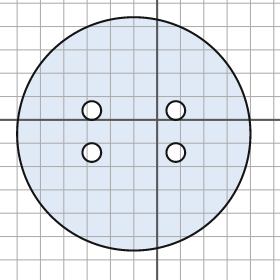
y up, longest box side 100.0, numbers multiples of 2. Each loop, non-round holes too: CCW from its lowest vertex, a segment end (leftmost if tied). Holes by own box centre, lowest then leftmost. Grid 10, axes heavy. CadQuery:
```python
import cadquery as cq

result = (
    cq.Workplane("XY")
    .moveTo(-10.0, -6.0)
    .circle(50.0)
    .moveTo(-28.0, -14.0)
    .circle(4.0)
    .moveTo(8.0, -14.0)
    .circle(4.0)
    .moveTo(-28.0, 4.0)
    .circle(4.0)
    .moveTo(8.0, 4.0)
    .circle(4.0)
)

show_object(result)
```